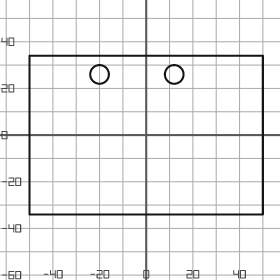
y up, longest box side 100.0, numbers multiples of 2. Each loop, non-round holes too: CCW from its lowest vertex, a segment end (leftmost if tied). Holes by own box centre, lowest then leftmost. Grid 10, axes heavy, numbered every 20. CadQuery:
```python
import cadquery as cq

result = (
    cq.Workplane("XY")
    .moveTo(-50.0, -34.0)
    .lineTo(50.0, -34.0)
    .lineTo(50.0, 34.0)
    .lineTo(-50.0, 34.0)
    .close()
    .moveTo(-20.0, 26.0)
    .circle(4.0)
    .moveTo(12.0, 26.0)
    .circle(4.0)
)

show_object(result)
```